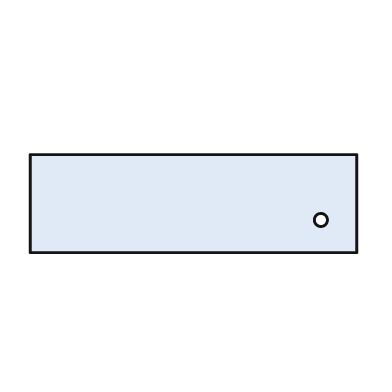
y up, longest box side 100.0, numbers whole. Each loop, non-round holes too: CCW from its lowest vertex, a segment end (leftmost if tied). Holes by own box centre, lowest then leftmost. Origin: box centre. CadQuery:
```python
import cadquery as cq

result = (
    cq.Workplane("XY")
    .moveTo(-50.0, -15.0)
    .lineTo(50.0, -15.0)
    .lineTo(50.0, 15.0)
    .lineTo(-50.0, 15.0)
    .close()
    .moveTo(39.0, -5.0)
    .circle(2.0)
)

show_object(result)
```